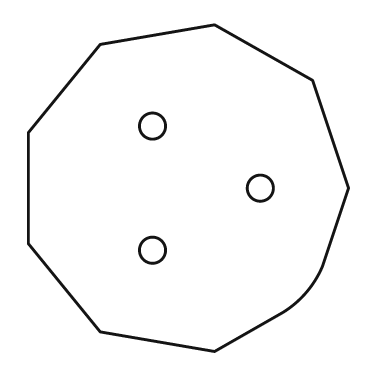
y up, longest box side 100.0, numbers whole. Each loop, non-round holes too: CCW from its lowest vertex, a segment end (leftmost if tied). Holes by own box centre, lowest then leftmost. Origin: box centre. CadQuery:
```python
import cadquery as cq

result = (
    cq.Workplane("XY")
    .moveTo(8.0, -50.0)
    .lineTo(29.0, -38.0)
    .threePointArc((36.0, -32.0), (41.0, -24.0))
    .lineTo(49.0, 0.0)
    .lineTo(38.0, 33.0)
    .lineTo(8.0, 50.0)
    .lineTo(-27.0, 44.0)
    .lineTo(-49.0, 17.0)
    .lineTo(-49.0, -17.0)
    .lineTo(-27.0, -44.0)
    .close()
    .moveTo(-11.0, -19.0)
    .circle(4.0)
    .moveTo(22.0, 0.0)
    .circle(4.0)
    .moveTo(-11.0, 19.0)
    .circle(4.0)
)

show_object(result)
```